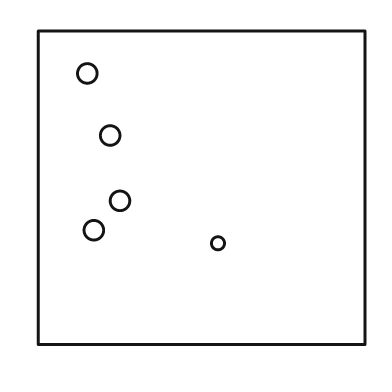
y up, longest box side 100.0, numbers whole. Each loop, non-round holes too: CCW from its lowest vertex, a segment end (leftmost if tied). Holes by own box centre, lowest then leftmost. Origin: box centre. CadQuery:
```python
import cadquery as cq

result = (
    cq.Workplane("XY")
    .moveTo(-50.0, -48.0)
    .lineTo(50.0, -48.0)
    .lineTo(50.0, 48.0)
    .lineTo(-50.0, 48.0)
    .close()
    .moveTo(5.0, -17.0)
    .circle(2.0)
    .moveTo(-33.0, -13.0)
    .circle(3.0)
    .moveTo(-25.0, -4.0)
    .circle(3.0)
    .moveTo(-28.0, 16.0)
    .circle(3.0)
    .moveTo(-35.0, 35.0)
    .circle(3.0)
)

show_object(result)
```